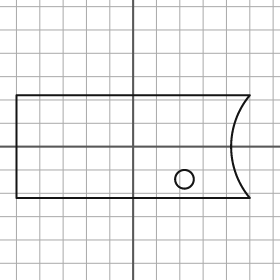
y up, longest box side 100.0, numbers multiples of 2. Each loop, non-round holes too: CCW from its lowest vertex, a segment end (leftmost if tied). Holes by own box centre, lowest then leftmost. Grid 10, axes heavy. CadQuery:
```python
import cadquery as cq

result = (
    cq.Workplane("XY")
    .moveTo(-50.0, -22.0)
    .lineTo(50.0, -22.0)
    .threePointArc((42.0, 0.0), (50.0, 22.0))
    .lineTo(-50.0, 22.0)
    .close()
    .moveTo(22.0, -14.0)
    .circle(4.0)
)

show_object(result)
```